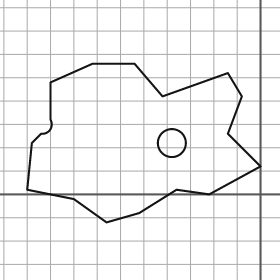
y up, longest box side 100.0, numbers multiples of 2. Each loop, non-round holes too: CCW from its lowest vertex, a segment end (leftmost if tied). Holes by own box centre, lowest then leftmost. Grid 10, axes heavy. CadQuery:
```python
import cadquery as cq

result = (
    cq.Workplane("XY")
    .moveTo(-66.0, -12.0)
    .lineTo(-52.0, -8.0)
    .lineTo(-36.0, 2.0)
    .lineTo(-22.0, 0.0)
    .lineTo(0.0, 12.0)
    .lineTo(-14.0, 26.0)
    .lineTo(-8.0, 42.0)
    .lineTo(-14.0, 52.0)
    .lineTo(-42.0, 42.0)
    .lineTo(-54.0, 56.0)
    .lineTo(-72.0, 56.0)
    .lineTo(-90.0, 48.0)
    .lineTo(-90.0, 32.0)
    .threePointArc((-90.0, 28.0), (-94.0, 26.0))
    .lineTo(-98.0, 22.0)
    .lineTo(-100.0, 2.0)
    .lineTo(-80.0, -2.0)
    .close()
    .moveTo(-38.0, 22.0)
    .circle(6.0)
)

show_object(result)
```